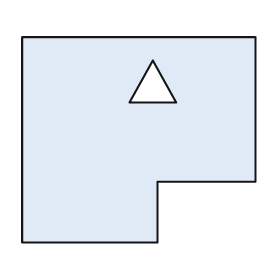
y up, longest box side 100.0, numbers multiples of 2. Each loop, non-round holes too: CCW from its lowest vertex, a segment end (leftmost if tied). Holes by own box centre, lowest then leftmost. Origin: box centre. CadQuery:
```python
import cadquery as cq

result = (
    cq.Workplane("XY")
    .moveTo(-50.0, -44.0)
    .lineTo(8.0, -44.0)
    .lineTo(8.0, -18.0)
    .lineTo(50.0, -18.0)
    .lineTo(50.0, 44.0)
    .lineTo(-50.0, 44.0)
    .close()
    .moveTo(-4.0, 16.0)
    .lineTo(16.0, 16.0)
    .lineTo(6.0, 34.0)
    .close()
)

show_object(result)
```